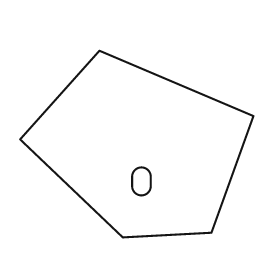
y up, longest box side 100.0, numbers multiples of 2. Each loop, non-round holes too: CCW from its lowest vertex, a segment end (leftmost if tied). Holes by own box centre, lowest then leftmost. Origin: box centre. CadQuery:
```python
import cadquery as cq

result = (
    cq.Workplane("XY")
    .moveTo(-6.0, -40.0)
    .lineTo(32.0, -38.0)
    .lineTo(50.0, 12.0)
    .lineTo(-16.0, 40.0)
    .lineTo(-50.0, 2.0)
    .close()
    .moveTo(-2.0, -18.0)
    .threePointArc((2.0, -22.0), (6.0, -18.0))
    .lineTo(6.0, -14.0)
    .threePointArc((2.0, -10.0), (-2.0, -14.0))
    .close()
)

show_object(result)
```